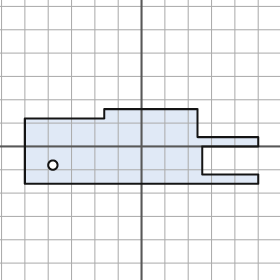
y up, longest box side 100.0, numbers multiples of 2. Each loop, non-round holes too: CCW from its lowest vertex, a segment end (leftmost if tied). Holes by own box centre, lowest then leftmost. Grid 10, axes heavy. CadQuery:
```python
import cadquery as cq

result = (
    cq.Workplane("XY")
    .moveTo(-50.0, -16.0)
    .lineTo(50.0, -16.0)
    .lineTo(50.0, -12.0)
    .lineTo(26.0, -12.0)
    .lineTo(26.0, 0.0)
    .lineTo(50.0, 0.0)
    .lineTo(50.0, 4.0)
    .lineTo(24.0, 4.0)
    .lineTo(24.0, 16.0)
    .lineTo(-16.0, 16.0)
    .lineTo(-16.0, 12.0)
    .lineTo(-50.0, 12.0)
    .close()
    .moveTo(-38.0, -8.0)
    .circle(2.0)
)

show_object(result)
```